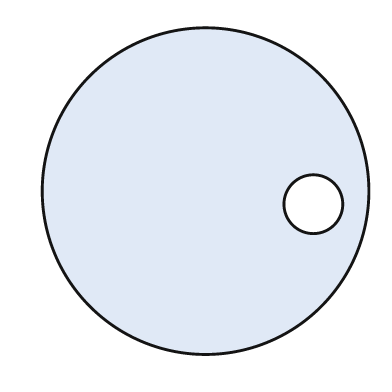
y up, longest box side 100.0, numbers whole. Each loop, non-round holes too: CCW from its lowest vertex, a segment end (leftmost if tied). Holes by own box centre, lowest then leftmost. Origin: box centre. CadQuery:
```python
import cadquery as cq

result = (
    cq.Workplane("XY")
    .moveTo(0.0, 0.0)
    .circle(50.0)
    .moveTo(33.0, -4.0)
    .circle(9.0)
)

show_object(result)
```